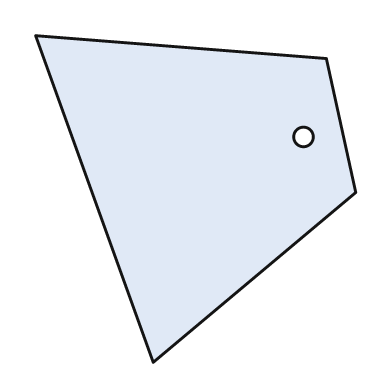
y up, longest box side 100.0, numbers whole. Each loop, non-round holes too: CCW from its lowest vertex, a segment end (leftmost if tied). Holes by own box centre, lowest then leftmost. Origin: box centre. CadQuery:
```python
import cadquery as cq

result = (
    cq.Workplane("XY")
    .moveTo(-13.0, -50.0)
    .lineTo(49.0, 2.0)
    .lineTo(40.0, 43.0)
    .lineTo(-49.0, 50.0)
    .close()
    .moveTo(33.0, 19.0)
    .circle(3.0)
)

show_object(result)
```